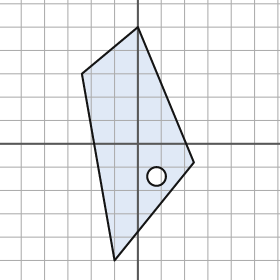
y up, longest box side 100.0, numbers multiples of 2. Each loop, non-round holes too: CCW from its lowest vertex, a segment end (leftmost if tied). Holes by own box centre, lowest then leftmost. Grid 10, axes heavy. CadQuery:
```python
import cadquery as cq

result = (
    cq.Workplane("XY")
    .moveTo(-10.0, -50.0)
    .lineTo(24.0, -8.0)
    .lineTo(0.0, 50.0)
    .lineTo(-24.0, 30.0)
    .close()
    .moveTo(8.0, -14.0)
    .circle(4.0)
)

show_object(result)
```